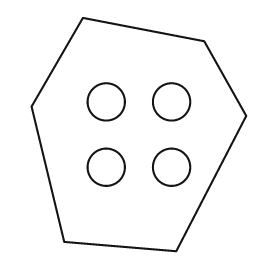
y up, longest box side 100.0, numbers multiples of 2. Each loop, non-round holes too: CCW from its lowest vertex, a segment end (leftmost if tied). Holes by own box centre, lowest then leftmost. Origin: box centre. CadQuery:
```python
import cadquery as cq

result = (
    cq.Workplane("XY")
    .moveTo(16.0, -50.0)
    .lineTo(46.0, 8.0)
    .lineTo(28.0, 40.0)
    .lineTo(-24.0, 50.0)
    .lineTo(-46.0, 12.0)
    .lineTo(-32.0, -46.0)
    .close()
    .moveTo(-14.0, -14.0)
    .circle(8.0)
    .moveTo(14.0, -14.0)
    .circle(8.0)
    .moveTo(-14.0, 14.0)
    .circle(8.0)
    .moveTo(14.0, 14.0)
    .circle(8.0)
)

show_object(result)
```